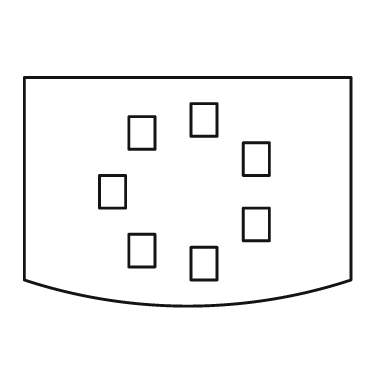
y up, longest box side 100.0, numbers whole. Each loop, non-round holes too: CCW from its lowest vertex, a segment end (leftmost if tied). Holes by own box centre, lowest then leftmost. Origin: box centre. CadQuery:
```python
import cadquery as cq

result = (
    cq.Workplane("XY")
    .moveTo(-50.0, -27.0)
    .threePointArc((0.0, -35.0), (50.0, -27.0))
    .lineTo(50.0, 35.0)
    .lineTo(-50.0, 35.0)
    .close()
    .moveTo(1.0, -27.0)
    .lineTo(9.0, -27.0)
    .lineTo(9.0, -17.0)
    .lineTo(1.0, -17.0)
    .close()
    .moveTo(-18.0, -23.0)
    .lineTo(-10.0, -23.0)
    .lineTo(-10.0, -13.0)
    .lineTo(-18.0, -13.0)
    .close()
    .moveTo(17.0, -15.0)
    .lineTo(25.0, -15.0)
    .lineTo(25.0, -5.0)
    .lineTo(17.0, -5.0)
    .close()
    .moveTo(-27.0, -5.0)
    .lineTo(-19.0, -5.0)
    .lineTo(-19.0, 5.0)
    .lineTo(-27.0, 5.0)
    .close()
    .moveTo(17.0, 5.0)
    .lineTo(25.0, 5.0)
    .lineTo(25.0, 15.0)
    .lineTo(17.0, 15.0)
    .close()
    .moveTo(-18.0, 13.0)
    .lineTo(-10.0, 13.0)
    .lineTo(-10.0, 23.0)
    .lineTo(-18.0, 23.0)
    .close()
    .moveTo(1.0, 17.0)
    .lineTo(9.0, 17.0)
    .lineTo(9.0, 27.0)
    .lineTo(1.0, 27.0)
    .close()
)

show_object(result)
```